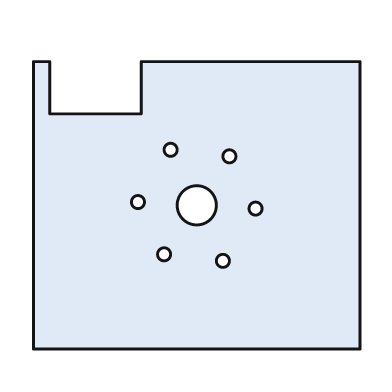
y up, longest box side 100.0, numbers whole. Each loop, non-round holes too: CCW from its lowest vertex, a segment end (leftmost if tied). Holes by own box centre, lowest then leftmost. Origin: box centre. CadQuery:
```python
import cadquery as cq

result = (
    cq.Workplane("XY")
    .moveTo(-50.0, -44.0)
    .lineTo(50.0, -44.0)
    .lineTo(50.0, 44.0)
    .lineTo(-17.0, 44.0)
    .lineTo(-17.0, 28.0)
    .lineTo(-45.0, 28.0)
    .lineTo(-45.0, 44.0)
    .lineTo(-50.0, 44.0)
    .close()
    .moveTo(8.0, -17.0)
    .circle(2.0)
    .moveTo(-10.0, -15.0)
    .circle(2.0)
    .moveTo(18.0, -1.0)
    .circle(2.0)
    .moveTo(0.0, 0.0)
    .circle(6.0)
    .moveTo(-18.0, 1.0)
    .circle(2.0)
    .moveTo(10.0, 15.0)
    .circle(2.0)
    .moveTo(-8.0, 17.0)
    .circle(2.0)
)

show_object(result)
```